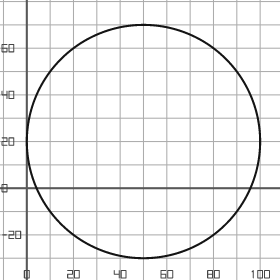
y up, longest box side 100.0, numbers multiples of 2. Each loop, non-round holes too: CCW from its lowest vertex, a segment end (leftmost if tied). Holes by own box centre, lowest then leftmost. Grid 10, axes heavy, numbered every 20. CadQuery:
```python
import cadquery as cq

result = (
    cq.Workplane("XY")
    .moveTo(50.0, 20.0)
    .circle(50.0)
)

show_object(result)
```